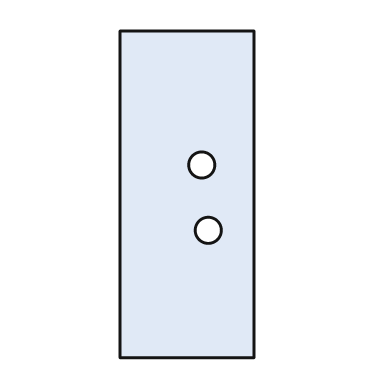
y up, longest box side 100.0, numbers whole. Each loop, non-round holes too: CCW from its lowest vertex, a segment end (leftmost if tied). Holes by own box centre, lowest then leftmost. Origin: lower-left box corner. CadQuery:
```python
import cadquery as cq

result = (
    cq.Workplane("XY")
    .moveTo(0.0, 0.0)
    .lineTo(41.0, 0.0)
    .lineTo(41.0, 100.0)
    .lineTo(0.0, 100.0)
    .close()
    .moveTo(27.0, 39.0)
    .circle(4.0)
    .moveTo(25.0, 59.0)
    .circle(4.0)
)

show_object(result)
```